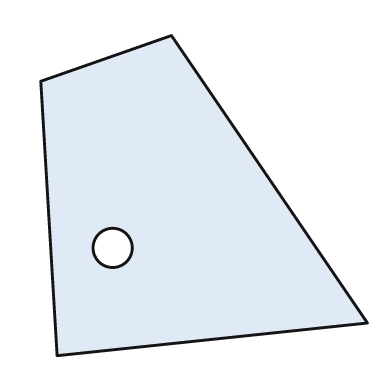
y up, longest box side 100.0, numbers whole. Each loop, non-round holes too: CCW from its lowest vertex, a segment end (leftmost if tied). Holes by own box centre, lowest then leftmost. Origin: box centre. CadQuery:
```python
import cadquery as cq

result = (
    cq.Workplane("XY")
    .moveTo(-45.0, -49.0)
    .lineTo(50.0, -39.0)
    .lineTo(-10.0, 49.0)
    .lineTo(-50.0, 35.0)
    .close()
    .moveTo(-28.0, -16.0)
    .circle(6.0)
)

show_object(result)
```